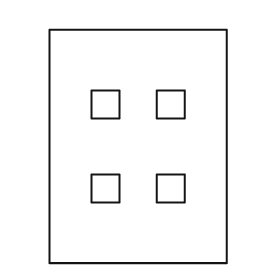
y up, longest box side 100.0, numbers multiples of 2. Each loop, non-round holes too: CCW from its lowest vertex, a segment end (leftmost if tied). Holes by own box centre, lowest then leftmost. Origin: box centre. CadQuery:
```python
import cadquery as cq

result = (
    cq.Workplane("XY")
    .moveTo(-38.0, -50.0)
    .lineTo(38.0, -50.0)
    .lineTo(38.0, 50.0)
    .lineTo(-38.0, 50.0)
    .close()
    .moveTo(-20.0, -24.0)
    .lineTo(-8.0, -24.0)
    .lineTo(-8.0, -12.0)
    .lineTo(-20.0, -12.0)
    .close()
    .moveTo(8.0, -24.0)
    .lineTo(20.0, -24.0)
    .lineTo(20.0, -12.0)
    .lineTo(8.0, -12.0)
    .close()
    .moveTo(-20.0, 12.0)
    .lineTo(-8.0, 12.0)
    .lineTo(-8.0, 24.0)
    .lineTo(-20.0, 24.0)
    .close()
    .moveTo(8.0, 12.0)
    .lineTo(20.0, 12.0)
    .lineTo(20.0, 24.0)
    .lineTo(8.0, 24.0)
    .close()
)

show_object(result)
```